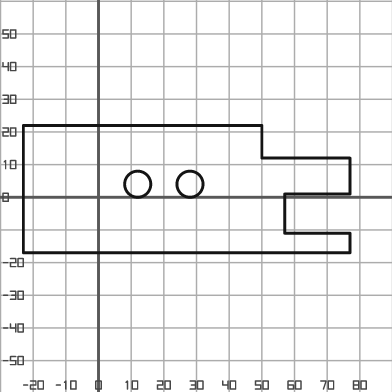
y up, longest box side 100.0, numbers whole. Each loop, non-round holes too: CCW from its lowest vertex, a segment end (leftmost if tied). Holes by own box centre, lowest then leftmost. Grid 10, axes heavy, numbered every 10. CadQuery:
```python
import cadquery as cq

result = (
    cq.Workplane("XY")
    .moveTo(-23.0, -17.0)
    .lineTo(77.0, -17.0)
    .lineTo(77.0, -11.0)
    .lineTo(57.0, -11.0)
    .lineTo(57.0, 1.0)
    .lineTo(77.0, 1.0)
    .lineTo(77.0, 12.0)
    .lineTo(50.0, 12.0)
    .lineTo(50.0, 22.0)
    .lineTo(-23.0, 22.0)
    .close()
    .moveTo(12.0, 4.0)
    .circle(4.0)
    .moveTo(28.0, 4.0)
    .circle(4.0)
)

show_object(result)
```